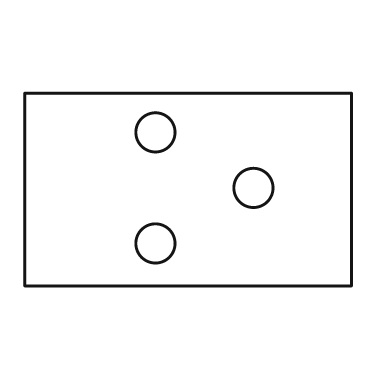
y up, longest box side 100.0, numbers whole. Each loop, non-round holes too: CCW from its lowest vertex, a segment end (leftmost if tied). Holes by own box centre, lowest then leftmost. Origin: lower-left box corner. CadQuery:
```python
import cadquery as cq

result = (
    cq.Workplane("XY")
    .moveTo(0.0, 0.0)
    .lineTo(100.0, 0.0)
    .lineTo(100.0, 59.0)
    .lineTo(0.0, 59.0)
    .close()
    .moveTo(40.0, 13.0)
    .circle(6.0)
    .moveTo(70.0, 30.0)
    .circle(6.0)
    .moveTo(40.0, 47.0)
    .circle(6.0)
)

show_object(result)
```